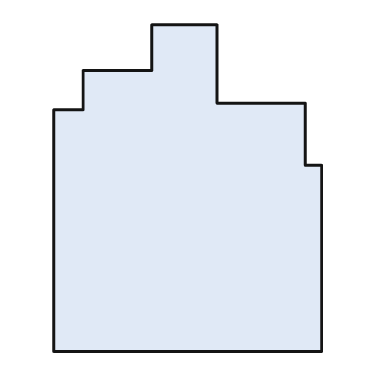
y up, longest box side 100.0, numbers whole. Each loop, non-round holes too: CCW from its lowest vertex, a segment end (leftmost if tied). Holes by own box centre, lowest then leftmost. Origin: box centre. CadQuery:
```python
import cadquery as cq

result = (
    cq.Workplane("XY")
    .moveTo(-41.0, -50.0)
    .lineTo(41.0, -50.0)
    .lineTo(41.0, 7.0)
    .lineTo(36.0, 7.0)
    .lineTo(36.0, 26.0)
    .lineTo(9.0, 26.0)
    .lineTo(9.0, 50.0)
    .lineTo(-11.0, 50.0)
    .lineTo(-11.0, 36.0)
    .lineTo(-32.0, 36.0)
    .lineTo(-32.0, 24.0)
    .lineTo(-41.0, 24.0)
    .close()
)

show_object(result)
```